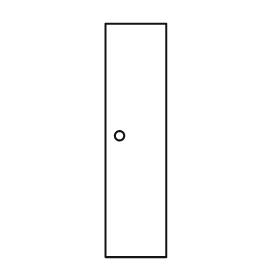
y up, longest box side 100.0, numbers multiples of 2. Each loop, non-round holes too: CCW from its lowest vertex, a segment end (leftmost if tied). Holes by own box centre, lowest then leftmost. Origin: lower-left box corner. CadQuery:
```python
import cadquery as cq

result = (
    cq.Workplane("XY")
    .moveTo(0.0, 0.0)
    .lineTo(26.0, 0.0)
    .lineTo(26.0, 100.0)
    .lineTo(0.0, 100.0)
    .close()
    .moveTo(6.0, 52.0)
    .circle(2.0)
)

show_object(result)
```